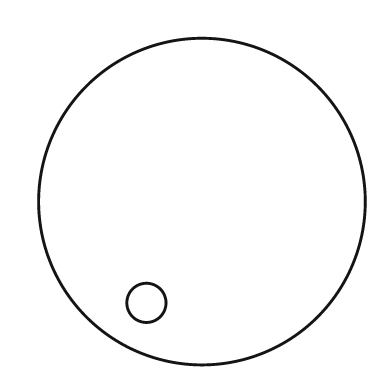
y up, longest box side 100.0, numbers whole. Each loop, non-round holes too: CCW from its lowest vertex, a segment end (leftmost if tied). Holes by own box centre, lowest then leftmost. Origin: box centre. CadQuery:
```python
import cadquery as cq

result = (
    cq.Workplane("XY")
    .moveTo(0.0, 0.0)
    .circle(50.0)
    .moveTo(-17.0, -31.0)
    .circle(6.0)
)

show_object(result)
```